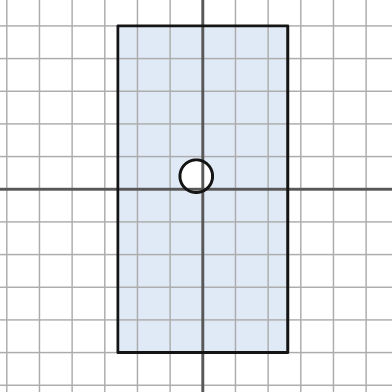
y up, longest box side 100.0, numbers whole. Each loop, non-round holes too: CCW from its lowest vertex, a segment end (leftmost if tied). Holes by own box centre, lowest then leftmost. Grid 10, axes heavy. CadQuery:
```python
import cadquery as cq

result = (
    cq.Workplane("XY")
    .moveTo(-26.0, -50.0)
    .lineTo(26.0, -50.0)
    .lineTo(26.0, 50.0)
    .lineTo(-26.0, 50.0)
    .close()
    .moveTo(-2.0, 4.0)
    .circle(5.0)
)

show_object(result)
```